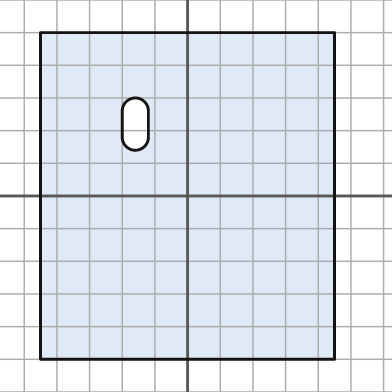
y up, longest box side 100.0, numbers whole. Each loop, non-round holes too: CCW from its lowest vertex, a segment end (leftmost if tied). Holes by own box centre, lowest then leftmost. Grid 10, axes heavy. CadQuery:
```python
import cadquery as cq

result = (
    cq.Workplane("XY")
    .moveTo(-45.0, -50.0)
    .lineTo(45.0, -50.0)
    .lineTo(45.0, 50.0)
    .lineTo(-45.0, 50.0)
    .close()
    .moveTo(-20.0, 18.0)
    .threePointArc((-16.0, 14.0), (-12.0, 18.0))
    .lineTo(-12.0, 26.0)
    .threePointArc((-16.0, 30.0), (-20.0, 26.0))
    .close()
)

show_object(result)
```